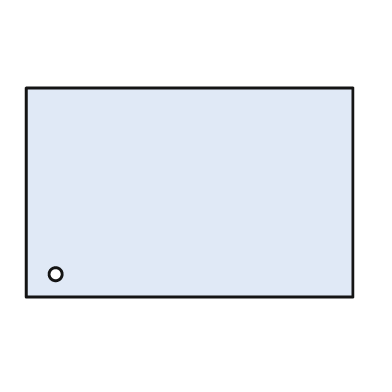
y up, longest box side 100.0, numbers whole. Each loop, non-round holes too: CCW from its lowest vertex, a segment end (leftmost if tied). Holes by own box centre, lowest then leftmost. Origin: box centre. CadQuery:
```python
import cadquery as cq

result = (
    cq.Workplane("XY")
    .moveTo(-50.0, -32.0)
    .lineTo(50.0, -32.0)
    .lineTo(50.0, 32.0)
    .lineTo(-50.0, 32.0)
    .close()
    .moveTo(-41.0, -25.0)
    .circle(2.0)
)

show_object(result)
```